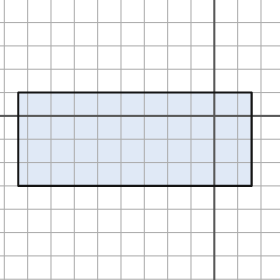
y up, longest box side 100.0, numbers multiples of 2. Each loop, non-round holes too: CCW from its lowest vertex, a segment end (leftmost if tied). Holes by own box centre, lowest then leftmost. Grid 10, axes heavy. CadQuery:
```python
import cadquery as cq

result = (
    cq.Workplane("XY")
    .moveTo(-84.0, -30.0)
    .lineTo(16.0, -30.0)
    .lineTo(16.0, 10.0)
    .lineTo(-84.0, 10.0)
    .close()
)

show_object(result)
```